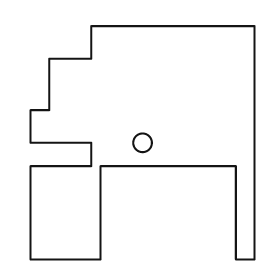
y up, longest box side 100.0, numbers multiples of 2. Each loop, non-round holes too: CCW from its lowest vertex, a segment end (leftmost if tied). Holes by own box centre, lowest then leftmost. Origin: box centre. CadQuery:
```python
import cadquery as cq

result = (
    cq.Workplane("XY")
    .moveTo(-48.0, -50.0)
    .lineTo(-18.0, -50.0)
    .lineTo(-18.0, -10.0)
    .lineTo(40.0, -10.0)
    .lineTo(40.0, -50.0)
    .lineTo(48.0, -50.0)
    .lineTo(48.0, 50.0)
    .lineTo(-22.0, 50.0)
    .lineTo(-22.0, 36.0)
    .lineTo(-40.0, 36.0)
    .lineTo(-40.0, 14.0)
    .lineTo(-48.0, 14.0)
    .lineTo(-48.0, 0.0)
    .lineTo(-22.0, 0.0)
    .lineTo(-22.0, -10.0)
    .lineTo(-48.0, -10.0)
    .close()
    .moveTo(0.0, 0.0)
    .circle(4.0)
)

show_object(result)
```